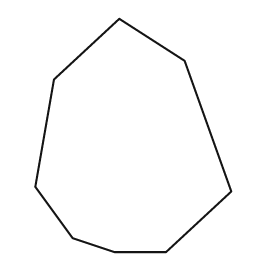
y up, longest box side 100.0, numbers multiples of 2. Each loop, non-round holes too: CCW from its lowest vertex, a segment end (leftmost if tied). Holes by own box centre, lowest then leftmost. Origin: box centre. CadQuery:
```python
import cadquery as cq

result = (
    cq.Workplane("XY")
    .moveTo(-8.0, -50.0)
    .lineTo(14.0, -50.0)
    .lineTo(42.0, -24.0)
    .lineTo(22.0, 32.0)
    .lineTo(-6.0, 50.0)
    .lineTo(-34.0, 24.0)
    .lineTo(-42.0, -22.0)
    .lineTo(-26.0, -44.0)
    .close()
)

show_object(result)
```